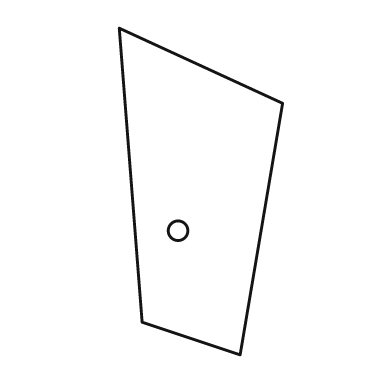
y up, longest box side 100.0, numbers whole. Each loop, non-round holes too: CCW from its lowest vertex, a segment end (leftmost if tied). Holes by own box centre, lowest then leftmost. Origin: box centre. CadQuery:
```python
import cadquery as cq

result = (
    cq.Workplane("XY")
    .moveTo(12.0, -50.0)
    .lineTo(25.0, 27.0)
    .lineTo(-25.0, 50.0)
    .lineTo(-18.0, -40.0)
    .close()
    .moveTo(-7.0, -12.0)
    .circle(3.0)
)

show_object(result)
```